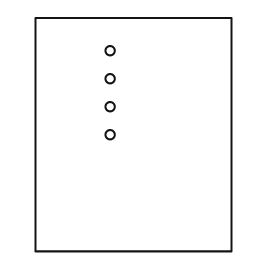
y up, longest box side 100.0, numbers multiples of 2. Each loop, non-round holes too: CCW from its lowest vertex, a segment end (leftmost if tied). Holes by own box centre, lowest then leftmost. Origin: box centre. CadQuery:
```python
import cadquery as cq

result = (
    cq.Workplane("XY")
    .moveTo(-42.0, -50.0)
    .lineTo(42.0, -50.0)
    .lineTo(42.0, 50.0)
    .lineTo(-42.0, 50.0)
    .close()
    .moveTo(-10.0, 0.0)
    .circle(2.0)
    .moveTo(-10.0, 12.0)
    .circle(2.0)
    .moveTo(-10.0, 24.0)
    .circle(2.0)
    .moveTo(-10.0, 36.0)
    .circle(2.0)
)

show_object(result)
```